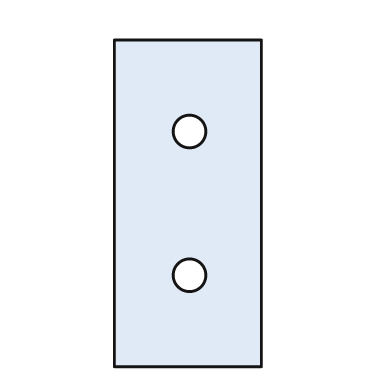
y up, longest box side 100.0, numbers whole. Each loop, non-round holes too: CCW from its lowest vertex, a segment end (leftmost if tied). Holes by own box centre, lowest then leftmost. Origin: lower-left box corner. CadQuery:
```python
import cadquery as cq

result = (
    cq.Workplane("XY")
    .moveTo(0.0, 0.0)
    .lineTo(45.0, 0.0)
    .lineTo(45.0, 100.0)
    .lineTo(0.0, 100.0)
    .close()
    .moveTo(23.0, 28.0)
    .circle(5.0)
    .moveTo(23.0, 72.0)
    .circle(5.0)
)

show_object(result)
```